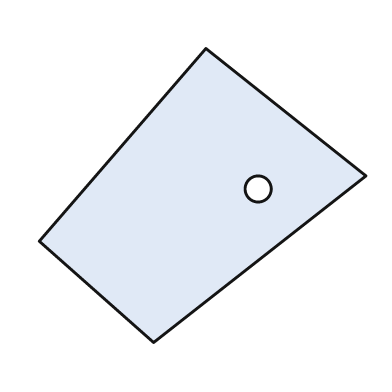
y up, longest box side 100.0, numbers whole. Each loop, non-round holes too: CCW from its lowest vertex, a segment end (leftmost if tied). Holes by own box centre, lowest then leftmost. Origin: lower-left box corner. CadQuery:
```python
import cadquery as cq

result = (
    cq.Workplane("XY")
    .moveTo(35.0, 0.0)
    .lineTo(100.0, 51.0)
    .lineTo(51.0, 90.0)
    .lineTo(0.0, 31.0)
    .close()
    .moveTo(67.0, 47.0)
    .circle(4.0)
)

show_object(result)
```